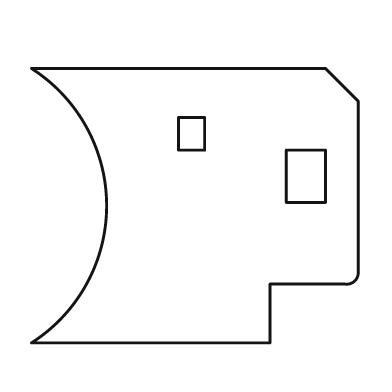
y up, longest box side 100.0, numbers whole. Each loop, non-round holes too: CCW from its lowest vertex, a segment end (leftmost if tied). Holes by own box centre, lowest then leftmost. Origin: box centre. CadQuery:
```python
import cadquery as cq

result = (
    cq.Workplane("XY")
    .moveTo(-50.0, -42.0)
    .lineTo(23.0, -42.0)
    .lineTo(23.0, -24.0)
    .lineTo(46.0, -24.0)
    .threePointArc((49.0, -23.0), (50.0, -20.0))
    .lineTo(50.0, 32.0)
    .lineTo(40.0, 42.0)
    .lineTo(-50.0, 42.0)
    .threePointArc((-27.0, 0.0), (-50.0, -42.0))
    .close()
    .moveTo(28.0, 1.0)
    .lineTo(40.0, 1.0)
    .lineTo(40.0, 17.0)
    .lineTo(28.0, 17.0)
    .close()
    .moveTo(-5.0, 17.0)
    .lineTo(3.0, 17.0)
    .lineTo(3.0, 27.0)
    .lineTo(-5.0, 27.0)
    .close()
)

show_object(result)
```